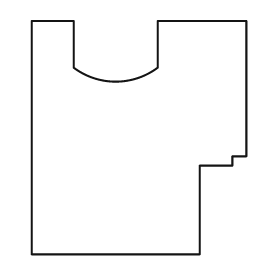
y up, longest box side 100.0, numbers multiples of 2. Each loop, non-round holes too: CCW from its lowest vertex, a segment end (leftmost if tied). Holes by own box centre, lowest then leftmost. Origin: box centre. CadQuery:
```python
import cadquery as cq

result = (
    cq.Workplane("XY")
    .moveTo(-46.0, -50.0)
    .lineTo(26.0, -50.0)
    .lineTo(26.0, -12.0)
    .lineTo(40.0, -12.0)
    .lineTo(40.0, -8.0)
    .lineTo(46.0, -8.0)
    .lineTo(46.0, 50.0)
    .lineTo(8.0, 50.0)
    .lineTo(8.0, 30.0)
    .threePointArc((-10.0, 24.0), (-28.0, 30.0))
    .lineTo(-28.0, 50.0)
    .lineTo(-46.0, 50.0)
    .close()
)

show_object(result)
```